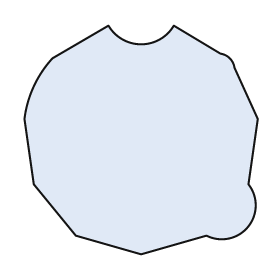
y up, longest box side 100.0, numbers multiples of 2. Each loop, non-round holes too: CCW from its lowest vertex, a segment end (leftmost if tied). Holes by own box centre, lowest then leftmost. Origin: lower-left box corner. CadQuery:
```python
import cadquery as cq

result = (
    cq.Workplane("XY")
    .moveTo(50.0, 0.0)
    .lineTo(78.0, 8.0)
    .threePointArc((96.0, 12.0), (96.0, 30.0))
    .lineTo(100.0, 58.0)
    .lineTo(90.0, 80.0)
    .threePointArc((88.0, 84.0), (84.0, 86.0))
    .lineTo(64.0, 98.0)
    .threePointArc((50.0, 90.0), (36.0, 98.0))
    .lineTo(12.0, 84.0)
    .threePointArc((4.0, 72.0), (0.0, 58.0))
    .lineTo(4.0, 30.0)
    .lineTo(22.0, 8.0)
    .close()
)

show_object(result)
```